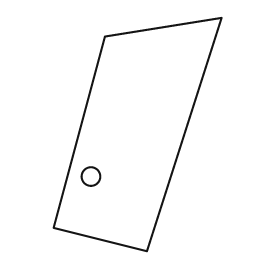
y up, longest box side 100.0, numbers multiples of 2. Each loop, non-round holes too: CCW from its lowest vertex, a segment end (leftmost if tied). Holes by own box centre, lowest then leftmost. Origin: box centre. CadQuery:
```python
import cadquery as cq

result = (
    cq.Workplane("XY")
    .moveTo(4.0, -50.0)
    .lineTo(36.0, 50.0)
    .lineTo(-14.0, 42.0)
    .lineTo(-36.0, -40.0)
    .close()
    .moveTo(-20.0, -18.0)
    .circle(4.0)
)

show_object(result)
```